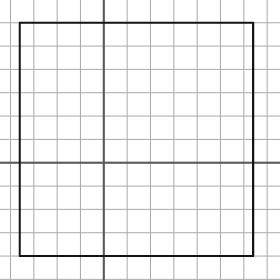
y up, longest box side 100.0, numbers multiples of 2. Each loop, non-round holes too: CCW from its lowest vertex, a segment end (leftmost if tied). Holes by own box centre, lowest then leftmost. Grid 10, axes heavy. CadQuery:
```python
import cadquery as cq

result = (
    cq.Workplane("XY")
    .moveTo(-36.0, -40.0)
    .lineTo(64.0, -40.0)
    .lineTo(64.0, 60.0)
    .lineTo(-36.0, 60.0)
    .close()
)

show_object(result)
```